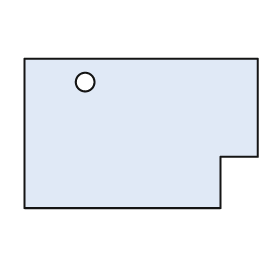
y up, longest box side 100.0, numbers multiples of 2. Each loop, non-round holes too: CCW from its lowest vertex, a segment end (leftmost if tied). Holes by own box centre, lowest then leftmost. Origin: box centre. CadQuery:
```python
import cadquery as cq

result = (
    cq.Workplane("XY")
    .moveTo(-50.0, -32.0)
    .lineTo(34.0, -32.0)
    .lineTo(34.0, -10.0)
    .lineTo(50.0, -10.0)
    .lineTo(50.0, 32.0)
    .lineTo(-50.0, 32.0)
    .close()
    .moveTo(-24.0, 22.0)
    .circle(4.0)
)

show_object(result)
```